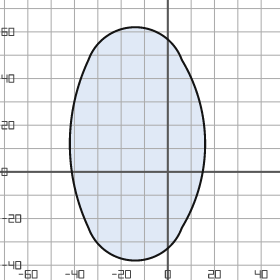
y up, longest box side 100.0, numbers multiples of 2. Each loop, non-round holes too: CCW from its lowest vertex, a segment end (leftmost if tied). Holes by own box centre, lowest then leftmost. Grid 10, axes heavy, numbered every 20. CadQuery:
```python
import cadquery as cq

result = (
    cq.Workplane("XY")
    .moveTo(-34.0, -24.0)
    .threePointArc((-14.0, -38.0), (6.0, -24.0))
    .threePointArc((16.0, 12.0), (6.0, 48.0))
    .threePointArc((-14.0, 62.0), (-34.0, 48.0))
    .threePointArc((-42.0, 12.0), (-34.0, -24.0))
    .close()
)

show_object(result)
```